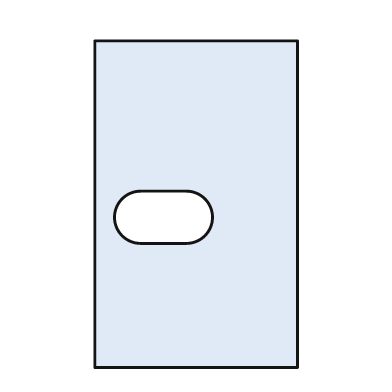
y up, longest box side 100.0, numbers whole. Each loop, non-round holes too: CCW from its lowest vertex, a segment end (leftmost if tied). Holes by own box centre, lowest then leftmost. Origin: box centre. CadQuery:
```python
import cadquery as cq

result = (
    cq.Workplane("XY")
    .moveTo(-31.0, -50.0)
    .lineTo(31.0, -50.0)
    .lineTo(31.0, 50.0)
    .lineTo(-31.0, 50.0)
    .close()
    .moveTo(-17.0, -12.0)
    .lineTo(-3.0, -12.0)
    .threePointArc((5.0, -4.0), (-3.0, 4.0))
    .lineTo(-17.0, 4.0)
    .threePointArc((-25.0, -4.0), (-17.0, -12.0))
    .close()
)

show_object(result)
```